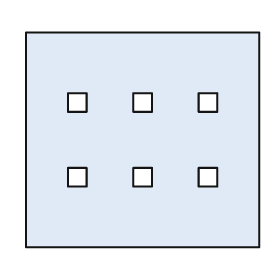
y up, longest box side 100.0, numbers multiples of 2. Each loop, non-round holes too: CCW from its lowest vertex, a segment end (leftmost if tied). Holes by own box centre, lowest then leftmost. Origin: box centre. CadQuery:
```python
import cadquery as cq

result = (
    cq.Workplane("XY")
    .moveTo(-50.0, -46.0)
    .lineTo(50.0, -46.0)
    .lineTo(50.0, 46.0)
    .lineTo(-50.0, 46.0)
    .close()
    .moveTo(-32.0, -20.0)
    .lineTo(-24.0, -20.0)
    .lineTo(-24.0, -12.0)
    .lineTo(-32.0, -12.0)
    .close()
    .moveTo(-4.0, -20.0)
    .lineTo(4.0, -20.0)
    .lineTo(4.0, -12.0)
    .lineTo(-4.0, -12.0)
    .close()
    .moveTo(24.0, -20.0)
    .lineTo(32.0, -20.0)
    .lineTo(32.0, -12.0)
    .lineTo(24.0, -12.0)
    .close()
    .moveTo(-32.0, 12.0)
    .lineTo(-24.0, 12.0)
    .lineTo(-24.0, 20.0)
    .lineTo(-32.0, 20.0)
    .close()
    .moveTo(-4.0, 12.0)
    .lineTo(4.0, 12.0)
    .lineTo(4.0, 20.0)
    .lineTo(-4.0, 20.0)
    .close()
    .moveTo(24.0, 12.0)
    .lineTo(32.0, 12.0)
    .lineTo(32.0, 20.0)
    .lineTo(24.0, 20.0)
    .close()
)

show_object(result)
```